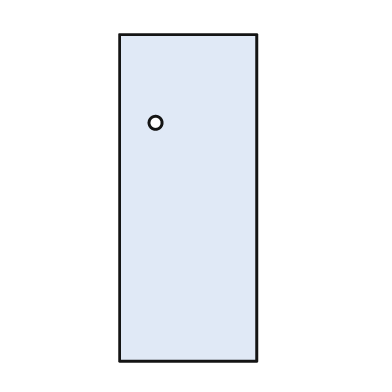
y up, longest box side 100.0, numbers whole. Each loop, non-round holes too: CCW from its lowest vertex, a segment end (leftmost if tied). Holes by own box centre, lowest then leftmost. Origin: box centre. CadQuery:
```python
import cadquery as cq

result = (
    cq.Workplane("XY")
    .moveTo(-21.0, -50.0)
    .lineTo(21.0, -50.0)
    .lineTo(21.0, 50.0)
    .lineTo(-21.0, 50.0)
    .close()
    .moveTo(-10.0, 23.0)
    .circle(2.0)
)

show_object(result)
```